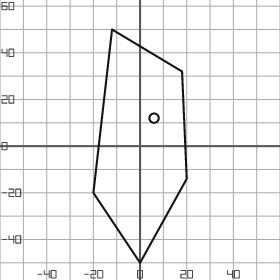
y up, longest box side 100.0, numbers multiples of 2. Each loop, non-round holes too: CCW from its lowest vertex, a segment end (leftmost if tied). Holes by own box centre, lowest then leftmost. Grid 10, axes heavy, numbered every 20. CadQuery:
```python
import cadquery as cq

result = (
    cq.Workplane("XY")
    .moveTo(0.0, -50.0)
    .lineTo(20.0, -14.0)
    .lineTo(18.0, 32.0)
    .lineTo(-12.0, 50.0)
    .lineTo(-20.0, -20.0)
    .close()
    .moveTo(6.0, 12.0)
    .circle(2.0)
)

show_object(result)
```